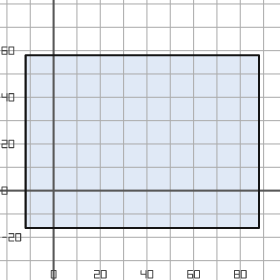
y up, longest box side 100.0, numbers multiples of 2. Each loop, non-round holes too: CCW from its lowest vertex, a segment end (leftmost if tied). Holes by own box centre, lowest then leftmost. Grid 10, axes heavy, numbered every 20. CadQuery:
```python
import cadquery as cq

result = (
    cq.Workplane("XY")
    .moveTo(-12.0, -16.0)
    .lineTo(88.0, -16.0)
    .lineTo(88.0, 58.0)
    .lineTo(-12.0, 58.0)
    .close()
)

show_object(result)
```